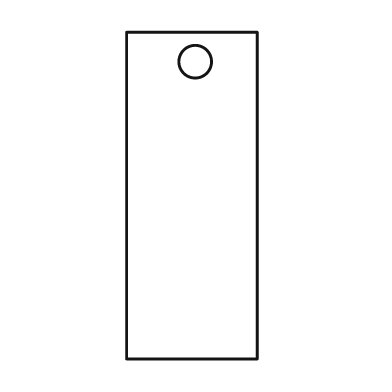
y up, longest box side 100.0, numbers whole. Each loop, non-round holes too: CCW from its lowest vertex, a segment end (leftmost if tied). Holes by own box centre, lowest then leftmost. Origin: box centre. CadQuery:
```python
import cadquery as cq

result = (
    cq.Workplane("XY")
    .moveTo(-20.0, -50.0)
    .lineTo(20.0, -50.0)
    .lineTo(20.0, 50.0)
    .lineTo(-20.0, 50.0)
    .close()
    .moveTo(1.0, 41.0)
    .circle(5.0)
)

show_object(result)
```